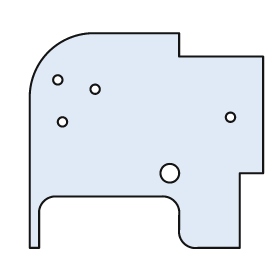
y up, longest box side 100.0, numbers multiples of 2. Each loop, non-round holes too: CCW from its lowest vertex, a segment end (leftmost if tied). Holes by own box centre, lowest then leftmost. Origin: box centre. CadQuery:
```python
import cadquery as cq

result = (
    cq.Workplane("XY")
    .moveTo(-50.0, -46.0)
    .lineTo(-46.0, -46.0)
    .lineTo(-46.0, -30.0)
    .threePointArc((-44.0, -26.0), (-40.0, -24.0))
    .lineTo(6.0, -24.0)
    .threePointArc((12.0, -26.0), (14.0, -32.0))
    .lineTo(14.0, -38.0)
    .threePointArc((16.0, -44.0), (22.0, -46.0))
    .lineTo(40.0, -46.0)
    .lineTo(40.0, -14.0)
    .lineTo(50.0, -14.0)
    .lineTo(50.0, 36.0)
    .lineTo(14.0, 36.0)
    .lineTo(14.0, 46.0)
    .lineTo(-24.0, 46.0)
    .threePointArc((-42.0, 38.0), (-50.0, 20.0))
    .close()
    .moveTo(10.0, -14.0)
    .circle(4.0)
    .moveTo(-36.0, 8.0)
    .circle(2.0)
    .moveTo(36.0, 10.0)
    .circle(2.0)
    .moveTo(-22.0, 22.0)
    .circle(2.0)
    .moveTo(-38.0, 26.0)
    .circle(2.0)
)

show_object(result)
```